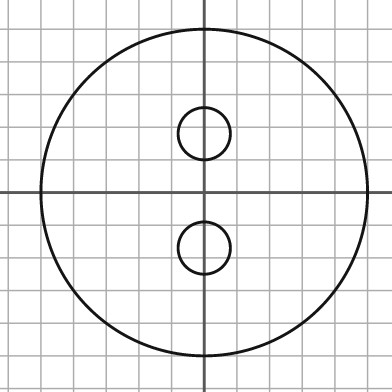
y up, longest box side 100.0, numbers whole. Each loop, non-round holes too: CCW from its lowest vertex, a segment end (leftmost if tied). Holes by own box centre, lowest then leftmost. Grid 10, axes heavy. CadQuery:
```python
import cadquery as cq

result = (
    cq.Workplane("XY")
    .moveTo(0.0, 0.0)
    .circle(50.0)
    .moveTo(0.0, -17.0)
    .circle(8.0)
    .moveTo(0.0, 18.0)
    .circle(8.0)
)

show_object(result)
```